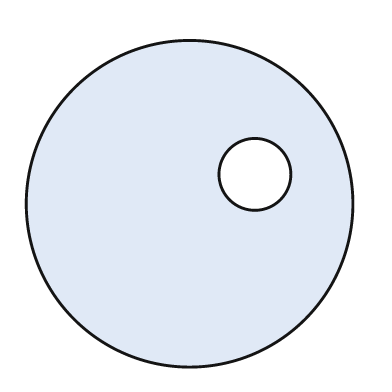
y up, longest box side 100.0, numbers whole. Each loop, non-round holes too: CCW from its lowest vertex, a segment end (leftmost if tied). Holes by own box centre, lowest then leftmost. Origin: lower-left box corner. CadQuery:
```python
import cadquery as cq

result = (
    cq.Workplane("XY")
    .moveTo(50.0, 50.0)
    .circle(50.0)
    .moveTo(70.0, 59.0)
    .circle(11.0)
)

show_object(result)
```